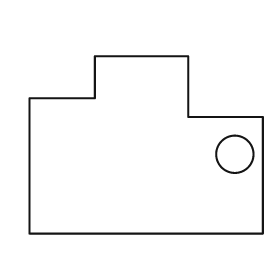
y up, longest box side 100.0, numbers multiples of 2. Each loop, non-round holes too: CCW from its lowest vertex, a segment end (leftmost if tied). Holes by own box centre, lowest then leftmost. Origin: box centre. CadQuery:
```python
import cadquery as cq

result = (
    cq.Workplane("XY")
    .moveTo(-50.0, -38.0)
    .lineTo(50.0, -38.0)
    .lineTo(50.0, 12.0)
    .lineTo(18.0, 12.0)
    .lineTo(18.0, 38.0)
    .lineTo(-22.0, 38.0)
    .lineTo(-22.0, 20.0)
    .lineTo(-50.0, 20.0)
    .close()
    .moveTo(38.0, -4.0)
    .circle(8.0)
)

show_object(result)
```